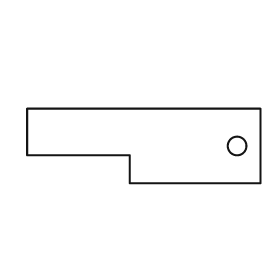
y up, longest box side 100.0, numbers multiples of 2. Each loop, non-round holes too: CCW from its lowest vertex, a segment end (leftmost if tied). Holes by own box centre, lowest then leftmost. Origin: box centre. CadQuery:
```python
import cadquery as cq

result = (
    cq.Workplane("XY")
    .moveTo(-6.0, -16.0)
    .lineTo(50.0, -16.0)
    .lineTo(50.0, 16.0)
    .lineTo(-50.0, 16.0)
    .lineTo(-50.0, -4.0)
    .lineTo(-6.0, -4.0)
    .close()
    .moveTo(40.0, 0.0)
    .circle(4.0)
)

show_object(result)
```